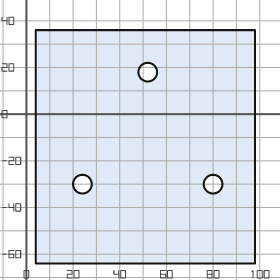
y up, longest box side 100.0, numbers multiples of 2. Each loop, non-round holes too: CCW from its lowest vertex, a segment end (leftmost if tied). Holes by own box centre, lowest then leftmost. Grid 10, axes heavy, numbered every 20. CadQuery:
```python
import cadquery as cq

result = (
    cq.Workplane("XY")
    .moveTo(4.0, -64.0)
    .lineTo(98.0, -64.0)
    .lineTo(98.0, 36.0)
    .lineTo(4.0, 36.0)
    .close()
    .moveTo(24.0, -30.0)
    .circle(4.0)
    .moveTo(80.0, -30.0)
    .circle(4.0)
    .moveTo(52.0, 18.0)
    .circle(4.0)
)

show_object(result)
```